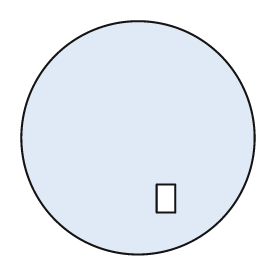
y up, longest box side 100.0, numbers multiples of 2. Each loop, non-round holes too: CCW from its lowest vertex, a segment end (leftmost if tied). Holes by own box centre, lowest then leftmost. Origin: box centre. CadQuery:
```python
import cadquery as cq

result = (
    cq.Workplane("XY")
    .moveTo(0.0, 0.0)
    .circle(50.0)
    .moveTo(8.0, -32.0)
    .lineTo(16.0, -32.0)
    .lineTo(16.0, -20.0)
    .lineTo(8.0, -20.0)
    .close()
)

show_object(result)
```